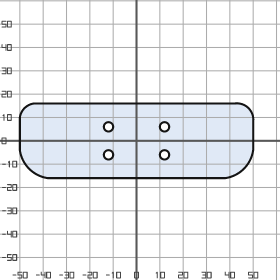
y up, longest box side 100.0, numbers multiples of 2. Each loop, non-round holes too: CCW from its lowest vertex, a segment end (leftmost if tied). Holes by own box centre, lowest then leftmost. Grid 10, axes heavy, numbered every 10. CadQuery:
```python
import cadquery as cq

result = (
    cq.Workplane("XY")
    .moveTo(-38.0, -16.0)
    .lineTo(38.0, -16.0)
    .threePointArc((46.0, -12.0), (50.0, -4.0))
    .lineTo(50.0, 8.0)
    .threePointArc((48.0, 14.0), (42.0, 16.0))
    .lineTo(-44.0, 16.0)
    .threePointArc((-48.0, 14.0), (-50.0, 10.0))
    .lineTo(-50.0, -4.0)
    .threePointArc((-46.0, -12.0), (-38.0, -16.0))
    .close()
    .moveTo(-12.0, -6.0)
    .circle(2.0)
    .moveTo(12.0, -6.0)
    .circle(2.0)
    .moveTo(-12.0, 6.0)
    .circle(2.0)
    .moveTo(12.0, 6.0)
    .circle(2.0)
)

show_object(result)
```